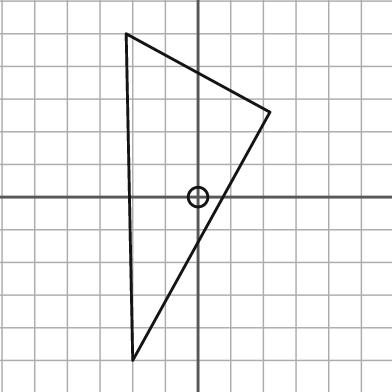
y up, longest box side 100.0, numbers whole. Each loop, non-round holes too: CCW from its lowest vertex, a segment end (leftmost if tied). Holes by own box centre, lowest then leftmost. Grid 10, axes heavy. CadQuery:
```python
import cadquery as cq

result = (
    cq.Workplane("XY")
    .moveTo(-20.0, -50.0)
    .lineTo(22.0, 26.0)
    .lineTo(-22.0, 50.0)
    .close()
    .moveTo(0.0, 0.0)
    .circle(3.0)
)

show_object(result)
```